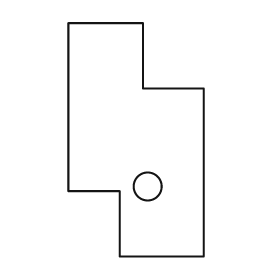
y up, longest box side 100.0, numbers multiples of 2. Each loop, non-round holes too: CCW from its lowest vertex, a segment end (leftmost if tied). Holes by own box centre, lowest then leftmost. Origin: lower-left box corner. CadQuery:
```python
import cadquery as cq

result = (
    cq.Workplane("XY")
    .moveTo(22.0, 0.0)
    .lineTo(58.0, 0.0)
    .lineTo(58.0, 72.0)
    .lineTo(32.0, 72.0)
    .lineTo(32.0, 100.0)
    .lineTo(0.0, 100.0)
    .lineTo(0.0, 28.0)
    .lineTo(22.0, 28.0)
    .close()
    .moveTo(34.0, 30.0)
    .circle(6.0)
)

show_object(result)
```